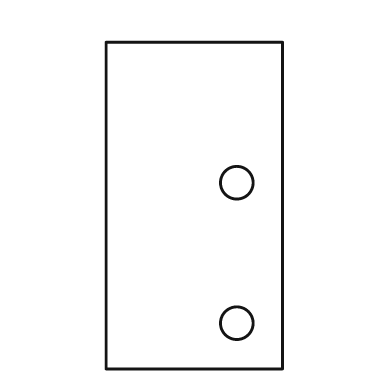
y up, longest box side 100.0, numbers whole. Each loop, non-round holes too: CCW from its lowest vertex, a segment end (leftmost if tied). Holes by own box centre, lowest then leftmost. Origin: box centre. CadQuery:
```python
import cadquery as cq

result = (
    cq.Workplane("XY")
    .moveTo(-27.0, -50.0)
    .lineTo(27.0, -50.0)
    .lineTo(27.0, 50.0)
    .lineTo(-27.0, 50.0)
    .close()
    .moveTo(13.0, -36.0)
    .circle(5.0)
    .moveTo(13.0, 7.0)
    .circle(5.0)
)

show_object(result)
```